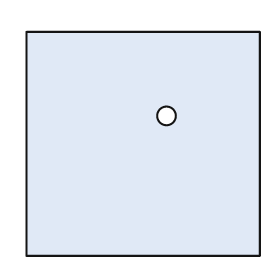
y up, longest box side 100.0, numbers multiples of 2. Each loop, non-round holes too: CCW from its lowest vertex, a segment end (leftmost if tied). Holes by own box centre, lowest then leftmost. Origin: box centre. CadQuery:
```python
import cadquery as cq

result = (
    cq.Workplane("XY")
    .moveTo(-50.0, -48.0)
    .lineTo(50.0, -48.0)
    .lineTo(50.0, 48.0)
    .lineTo(-50.0, 48.0)
    .close()
    .moveTo(10.0, 12.0)
    .circle(4.0)
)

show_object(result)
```